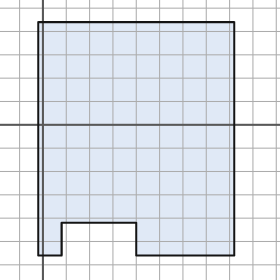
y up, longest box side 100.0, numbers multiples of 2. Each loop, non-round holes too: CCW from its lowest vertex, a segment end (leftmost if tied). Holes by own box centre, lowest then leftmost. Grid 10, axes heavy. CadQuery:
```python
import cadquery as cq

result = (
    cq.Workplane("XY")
    .moveTo(-2.0, -56.0)
    .lineTo(8.0, -56.0)
    .lineTo(8.0, -42.0)
    .lineTo(40.0, -42.0)
    .lineTo(40.0, -56.0)
    .lineTo(82.0, -56.0)
    .lineTo(82.0, 44.0)
    .lineTo(-2.0, 44.0)
    .close()
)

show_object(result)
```